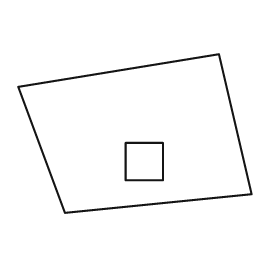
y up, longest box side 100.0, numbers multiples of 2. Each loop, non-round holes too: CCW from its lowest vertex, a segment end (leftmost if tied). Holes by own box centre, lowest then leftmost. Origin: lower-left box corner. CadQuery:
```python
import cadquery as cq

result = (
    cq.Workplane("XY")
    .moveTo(20.0, 0.0)
    .lineTo(100.0, 8.0)
    .lineTo(86.0, 68.0)
    .lineTo(0.0, 54.0)
    .close()
    .moveTo(46.0, 14.0)
    .lineTo(62.0, 14.0)
    .lineTo(62.0, 30.0)
    .lineTo(46.0, 30.0)
    .close()
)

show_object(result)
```